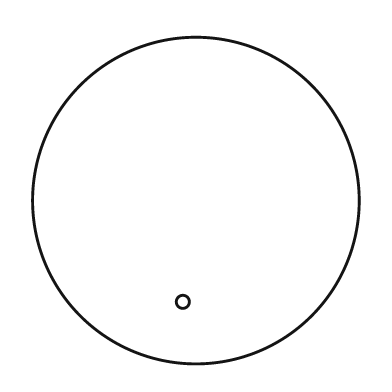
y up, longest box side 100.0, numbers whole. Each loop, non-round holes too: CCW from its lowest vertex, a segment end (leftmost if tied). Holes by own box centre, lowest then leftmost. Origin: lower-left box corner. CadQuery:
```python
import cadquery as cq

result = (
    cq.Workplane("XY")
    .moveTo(50.0, 50.0)
    .circle(50.0)
    .moveTo(46.0, 19.0)
    .circle(2.0)
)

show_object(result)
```